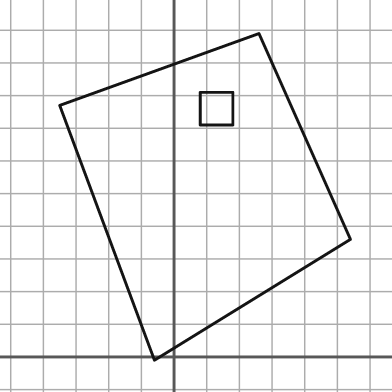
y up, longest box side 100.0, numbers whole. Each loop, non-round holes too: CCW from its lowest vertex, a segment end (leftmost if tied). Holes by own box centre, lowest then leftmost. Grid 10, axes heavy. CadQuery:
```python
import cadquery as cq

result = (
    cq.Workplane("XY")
    .moveTo(-6.0, -1.0)
    .lineTo(54.0, 36.0)
    .lineTo(26.0, 99.0)
    .lineTo(-35.0, 77.0)
    .close()
    .moveTo(8.0, 71.0)
    .lineTo(18.0, 71.0)
    .lineTo(18.0, 81.0)
    .lineTo(8.0, 81.0)
    .close()
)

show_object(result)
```